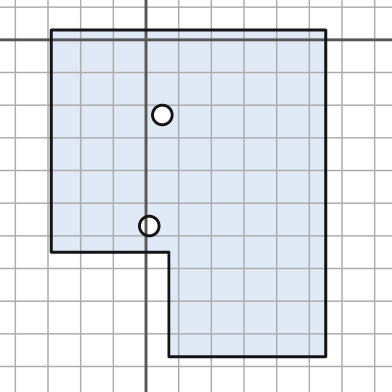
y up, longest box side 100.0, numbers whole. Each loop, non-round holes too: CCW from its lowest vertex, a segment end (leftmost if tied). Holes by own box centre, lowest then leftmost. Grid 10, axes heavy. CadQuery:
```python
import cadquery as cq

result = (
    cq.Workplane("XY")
    .moveTo(7.0, -97.0)
    .lineTo(55.0, -97.0)
    .lineTo(55.0, 3.0)
    .lineTo(-29.0, 3.0)
    .lineTo(-29.0, -65.0)
    .lineTo(7.0, -65.0)
    .close()
    .moveTo(1.0, -57.0)
    .circle(3.0)
    .moveTo(5.0, -23.0)
    .circle(3.0)
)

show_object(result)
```